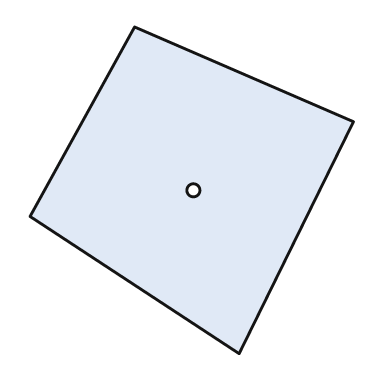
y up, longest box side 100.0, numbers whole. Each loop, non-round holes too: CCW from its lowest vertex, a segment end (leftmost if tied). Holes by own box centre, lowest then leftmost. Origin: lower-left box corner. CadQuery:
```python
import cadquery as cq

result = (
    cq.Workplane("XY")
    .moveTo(64.0, 0.0)
    .lineTo(99.0, 71.0)
    .lineTo(32.0, 100.0)
    .lineTo(0.0, 42.0)
    .close()
    .moveTo(50.0, 50.0)
    .circle(2.0)
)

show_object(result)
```